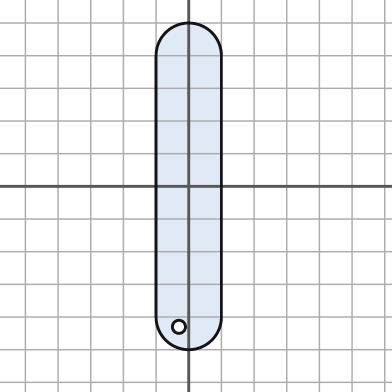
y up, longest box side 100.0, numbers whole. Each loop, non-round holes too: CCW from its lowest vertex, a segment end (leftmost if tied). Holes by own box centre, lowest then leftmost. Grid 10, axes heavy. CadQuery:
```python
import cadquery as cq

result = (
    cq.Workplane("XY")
    .moveTo(-10.0, -40.0)
    .threePointArc((0.0, -50.0), (10.0, -40.0))
    .lineTo(10.0, 40.0)
    .threePointArc((0.0, 50.0), (-10.0, 40.0))
    .close()
    .moveTo(-3.0, -43.0)
    .circle(2.0)
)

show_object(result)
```